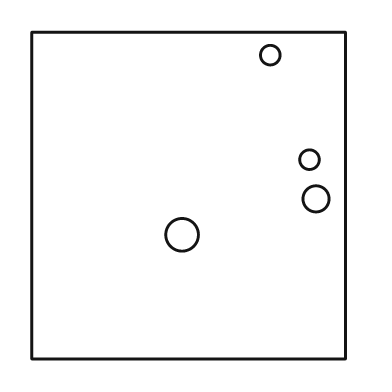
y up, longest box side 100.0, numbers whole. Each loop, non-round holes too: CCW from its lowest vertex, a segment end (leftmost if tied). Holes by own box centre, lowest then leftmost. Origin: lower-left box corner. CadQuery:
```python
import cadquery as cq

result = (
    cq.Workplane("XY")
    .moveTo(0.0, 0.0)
    .lineTo(96.0, 0.0)
    .lineTo(96.0, 100.0)
    .lineTo(0.0, 100.0)
    .close()
    .moveTo(46.0, 38.0)
    .circle(5.0)
    .moveTo(87.0, 49.0)
    .circle(4.0)
    .moveTo(85.0, 61.0)
    .circle(3.0)
    .moveTo(73.0, 93.0)
    .circle(3.0)
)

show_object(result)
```